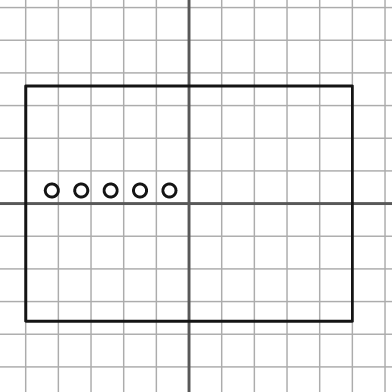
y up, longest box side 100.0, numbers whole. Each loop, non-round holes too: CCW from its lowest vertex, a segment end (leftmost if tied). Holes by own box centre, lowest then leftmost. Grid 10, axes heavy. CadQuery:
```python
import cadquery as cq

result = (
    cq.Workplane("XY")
    .moveTo(-50.0, -36.0)
    .lineTo(50.0, -36.0)
    .lineTo(50.0, 36.0)
    .lineTo(-50.0, 36.0)
    .close()
    .moveTo(-42.0, 4.0)
    .circle(2.0)
    .moveTo(-33.0, 4.0)
    .circle(2.0)
    .moveTo(-24.0, 4.0)
    .circle(2.0)
    .moveTo(-15.0, 4.0)
    .circle(2.0)
    .moveTo(-6.0, 4.0)
    .circle(2.0)
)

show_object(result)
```